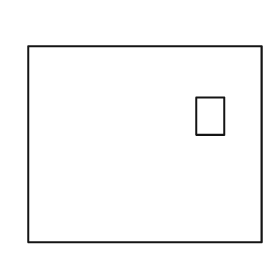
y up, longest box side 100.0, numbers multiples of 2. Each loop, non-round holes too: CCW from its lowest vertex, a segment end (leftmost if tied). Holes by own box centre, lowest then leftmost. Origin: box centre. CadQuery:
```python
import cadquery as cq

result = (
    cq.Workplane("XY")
    .moveTo(-50.0, -42.0)
    .lineTo(50.0, -42.0)
    .lineTo(50.0, 42.0)
    .lineTo(-50.0, 42.0)
    .close()
    .moveTo(22.0, 4.0)
    .lineTo(34.0, 4.0)
    .lineTo(34.0, 20.0)
    .lineTo(22.0, 20.0)
    .close()
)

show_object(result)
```